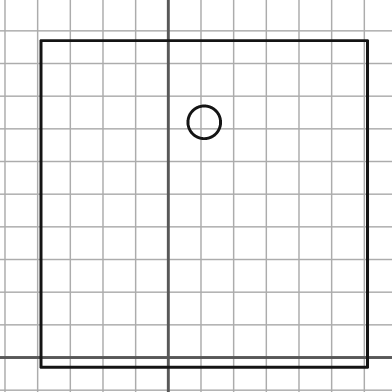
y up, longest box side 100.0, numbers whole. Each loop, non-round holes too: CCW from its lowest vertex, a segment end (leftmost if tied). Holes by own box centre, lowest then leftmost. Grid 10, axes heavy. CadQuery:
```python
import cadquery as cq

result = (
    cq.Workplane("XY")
    .moveTo(-39.0, -3.0)
    .lineTo(61.0, -3.0)
    .lineTo(61.0, 97.0)
    .lineTo(-39.0, 97.0)
    .close()
    .moveTo(11.0, 72.0)
    .circle(5.0)
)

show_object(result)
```